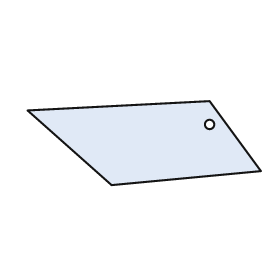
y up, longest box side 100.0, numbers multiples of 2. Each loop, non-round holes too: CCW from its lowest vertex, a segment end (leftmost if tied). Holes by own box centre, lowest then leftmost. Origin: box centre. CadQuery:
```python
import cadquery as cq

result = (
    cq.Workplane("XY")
    .moveTo(-14.0, -18.0)
    .lineTo(50.0, -12.0)
    .lineTo(28.0, 18.0)
    .lineTo(-50.0, 14.0)
    .close()
    .moveTo(28.0, 8.0)
    .circle(2.0)
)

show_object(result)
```